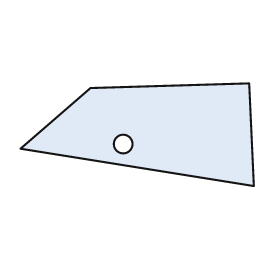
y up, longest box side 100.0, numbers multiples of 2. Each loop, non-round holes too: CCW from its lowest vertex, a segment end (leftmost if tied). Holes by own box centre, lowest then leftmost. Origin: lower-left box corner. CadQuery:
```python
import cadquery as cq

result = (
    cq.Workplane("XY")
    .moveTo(100.0, 0.0)
    .lineTo(98.0, 44.0)
    .lineTo(30.0, 42.0)
    .lineTo(0.0, 16.0)
    .close()
    .moveTo(44.0, 18.0)
    .circle(4.0)
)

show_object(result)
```